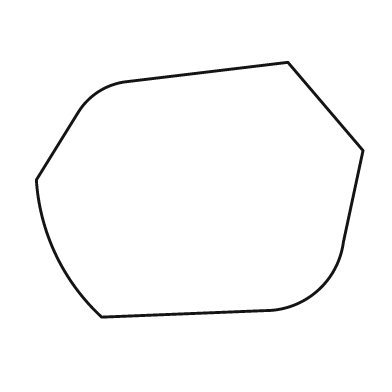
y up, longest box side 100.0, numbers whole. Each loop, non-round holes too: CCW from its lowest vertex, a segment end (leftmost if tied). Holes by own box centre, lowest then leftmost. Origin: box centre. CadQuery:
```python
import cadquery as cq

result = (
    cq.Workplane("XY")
    .moveTo(-30.0, -39.0)
    .lineTo(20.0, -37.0)
    .threePointArc((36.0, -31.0), (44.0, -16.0))
    .lineTo(50.0, 12.0)
    .lineTo(27.0, 39.0)
    .lineTo(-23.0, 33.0)
    .threePointArc((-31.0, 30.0), (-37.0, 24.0))
    .lineTo(-50.0, 3.0)
    .threePointArc((-44.0, -20.0), (-30.0, -39.0))
    .close()
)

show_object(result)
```